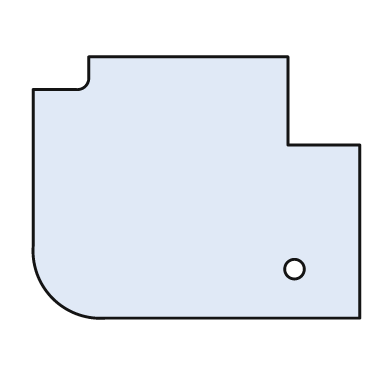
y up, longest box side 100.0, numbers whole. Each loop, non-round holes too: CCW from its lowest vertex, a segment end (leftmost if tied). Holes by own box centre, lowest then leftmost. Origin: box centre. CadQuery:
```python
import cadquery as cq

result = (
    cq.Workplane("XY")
    .moveTo(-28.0, -40.0)
    .lineTo(50.0, -40.0)
    .lineTo(50.0, 13.0)
    .lineTo(28.0, 13.0)
    .lineTo(28.0, 40.0)
    .lineTo(-33.0, 40.0)
    .lineTo(-33.0, 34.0)
    .threePointArc((-34.0, 31.0), (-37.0, 30.0))
    .lineTo(-50.0, 30.0)
    .lineTo(-50.0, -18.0)
    .threePointArc((-44.0, -34.0), (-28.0, -40.0))
    .close()
    .moveTo(30.0, -25.0)
    .circle(3.0)
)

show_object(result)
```